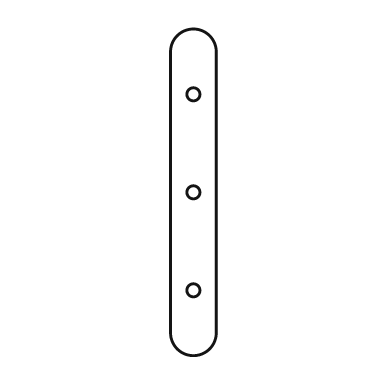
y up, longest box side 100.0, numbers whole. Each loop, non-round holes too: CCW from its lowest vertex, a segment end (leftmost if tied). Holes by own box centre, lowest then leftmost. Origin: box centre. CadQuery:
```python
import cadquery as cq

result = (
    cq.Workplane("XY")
    .moveTo(-7.0, -43.0)
    .threePointArc((0.0, -50.0), (7.0, -43.0))
    .lineTo(7.0, 43.0)
    .threePointArc((0.0, 50.0), (-7.0, 43.0))
    .close()
    .moveTo(0.0, -30.0)
    .circle(2.0)
    .moveTo(0.0, 0.0)
    .circle(2.0)
    .moveTo(0.0, 30.0)
    .circle(2.0)
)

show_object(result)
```